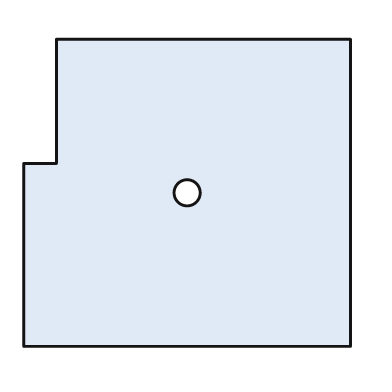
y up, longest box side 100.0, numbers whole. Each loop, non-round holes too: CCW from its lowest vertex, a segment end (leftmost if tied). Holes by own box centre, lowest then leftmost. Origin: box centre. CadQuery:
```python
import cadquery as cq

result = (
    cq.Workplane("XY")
    .moveTo(-50.0, -47.0)
    .lineTo(50.0, -47.0)
    .lineTo(50.0, 47.0)
    .lineTo(-40.0, 47.0)
    .lineTo(-40.0, 9.0)
    .lineTo(-50.0, 9.0)
    .close()
    .moveTo(0.0, 0.0)
    .circle(4.0)
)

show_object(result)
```